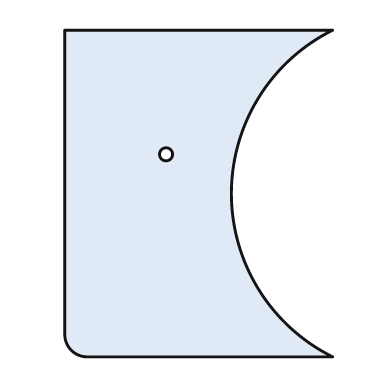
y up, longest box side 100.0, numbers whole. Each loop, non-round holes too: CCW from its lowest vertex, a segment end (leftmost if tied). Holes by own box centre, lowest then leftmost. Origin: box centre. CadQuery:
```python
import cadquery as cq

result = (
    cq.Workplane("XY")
    .moveTo(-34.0, -50.0)
    .lineTo(41.0, -50.0)
    .threePointArc((10.0, 0.0), (41.0, 50.0))
    .lineTo(-41.0, 50.0)
    .lineTo(-41.0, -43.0)
    .threePointArc((-39.0, -48.0), (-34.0, -50.0))
    .close()
    .moveTo(-10.0, 12.0)
    .circle(2.0)
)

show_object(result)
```